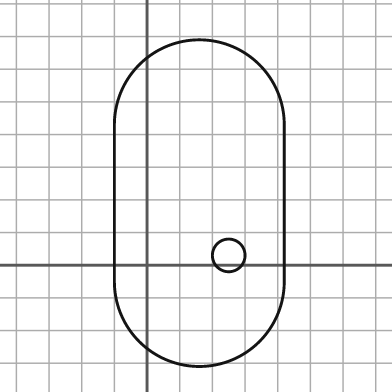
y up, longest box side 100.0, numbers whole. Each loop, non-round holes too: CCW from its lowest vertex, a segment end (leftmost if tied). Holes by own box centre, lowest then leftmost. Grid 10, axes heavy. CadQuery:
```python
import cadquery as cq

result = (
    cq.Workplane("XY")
    .moveTo(-10.0, -5.0)
    .threePointArc((16.0, -31.0), (42.0, -5.0))
    .lineTo(42.0, 43.0)
    .threePointArc((16.0, 69.0), (-10.0, 43.0))
    .close()
    .moveTo(25.0, 3.0)
    .circle(5.0)
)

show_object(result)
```